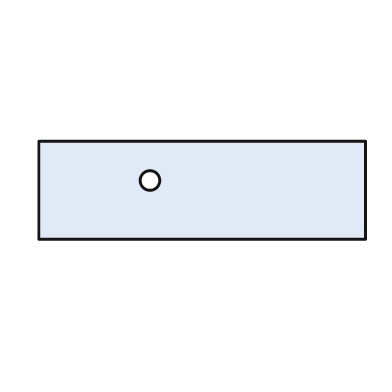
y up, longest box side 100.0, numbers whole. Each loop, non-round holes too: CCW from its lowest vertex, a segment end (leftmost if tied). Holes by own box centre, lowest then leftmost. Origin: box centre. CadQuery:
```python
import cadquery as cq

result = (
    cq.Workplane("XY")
    .moveTo(-50.0, -15.0)
    .lineTo(50.0, -15.0)
    .lineTo(50.0, 15.0)
    .lineTo(-50.0, 15.0)
    .close()
    .moveTo(-16.0, 3.0)
    .circle(3.0)
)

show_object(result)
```